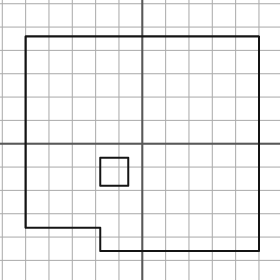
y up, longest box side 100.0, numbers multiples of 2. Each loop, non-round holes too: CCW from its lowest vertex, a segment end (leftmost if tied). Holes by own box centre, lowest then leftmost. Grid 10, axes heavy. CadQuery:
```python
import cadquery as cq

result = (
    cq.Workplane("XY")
    .moveTo(-18.0, -46.0)
    .lineTo(50.0, -46.0)
    .lineTo(50.0, 46.0)
    .lineTo(-50.0, 46.0)
    .lineTo(-50.0, -36.0)
    .lineTo(-18.0, -36.0)
    .close()
    .moveTo(-18.0, -18.0)
    .lineTo(-6.0, -18.0)
    .lineTo(-6.0, -6.0)
    .lineTo(-18.0, -6.0)
    .close()
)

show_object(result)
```